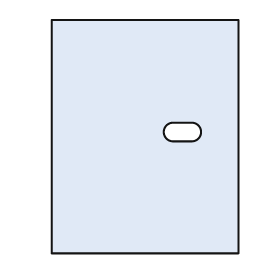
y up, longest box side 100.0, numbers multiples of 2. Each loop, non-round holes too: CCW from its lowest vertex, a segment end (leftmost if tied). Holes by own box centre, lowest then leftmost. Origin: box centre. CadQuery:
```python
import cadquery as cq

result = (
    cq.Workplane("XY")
    .moveTo(-40.0, -50.0)
    .lineTo(40.0, -50.0)
    .lineTo(40.0, 50.0)
    .lineTo(-40.0, 50.0)
    .close()
    .moveTo(12.0, -2.0)
    .lineTo(20.0, -2.0)
    .threePointArc((24.0, 2.0), (20.0, 6.0))
    .lineTo(12.0, 6.0)
    .threePointArc((8.0, 2.0), (12.0, -2.0))
    .close()
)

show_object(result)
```